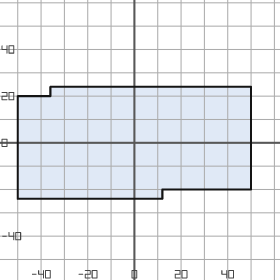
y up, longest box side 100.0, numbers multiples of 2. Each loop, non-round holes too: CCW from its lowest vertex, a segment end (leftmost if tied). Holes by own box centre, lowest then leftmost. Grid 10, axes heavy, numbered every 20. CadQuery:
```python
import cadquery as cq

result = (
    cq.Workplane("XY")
    .moveTo(-50.0, -24.0)
    .lineTo(12.0, -24.0)
    .lineTo(12.0, -20.0)
    .lineTo(50.0, -20.0)
    .lineTo(50.0, 24.0)
    .lineTo(-36.0, 24.0)
    .lineTo(-36.0, 20.0)
    .lineTo(-50.0, 20.0)
    .close()
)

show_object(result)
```